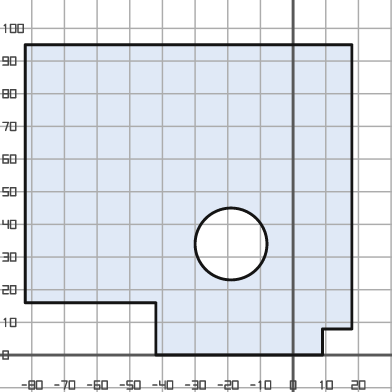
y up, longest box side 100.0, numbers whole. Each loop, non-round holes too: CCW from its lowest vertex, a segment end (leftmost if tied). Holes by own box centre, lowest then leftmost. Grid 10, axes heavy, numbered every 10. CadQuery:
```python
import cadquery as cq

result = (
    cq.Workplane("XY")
    .moveTo(-42.0, 0.0)
    .lineTo(9.0, 0.0)
    .lineTo(9.0, 8.0)
    .lineTo(18.0, 8.0)
    .lineTo(18.0, 95.0)
    .lineTo(-82.0, 95.0)
    .lineTo(-82.0, 16.0)
    .lineTo(-42.0, 16.0)
    .close()
    .moveTo(-19.0, 34.0)
    .circle(11.0)
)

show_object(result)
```